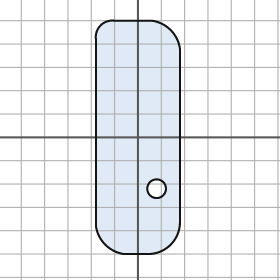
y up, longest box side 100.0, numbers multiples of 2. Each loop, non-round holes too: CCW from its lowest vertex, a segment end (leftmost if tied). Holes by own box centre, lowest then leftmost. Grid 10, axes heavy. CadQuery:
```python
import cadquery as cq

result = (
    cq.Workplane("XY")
    .moveTo(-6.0, -50.0)
    .lineTo(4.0, -50.0)
    .threePointArc((14.0, -46.0), (18.0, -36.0))
    .lineTo(18.0, 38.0)
    .threePointArc((14.0, 46.0), (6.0, 50.0))
    .lineTo(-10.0, 50.0)
    .threePointArc((-16.0, 48.0), (-18.0, 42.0))
    .lineTo(-18.0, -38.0)
    .threePointArc((-14.0, -46.0), (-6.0, -50.0))
    .close()
    .moveTo(8.0, -22.0)
    .circle(4.0)
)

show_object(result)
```